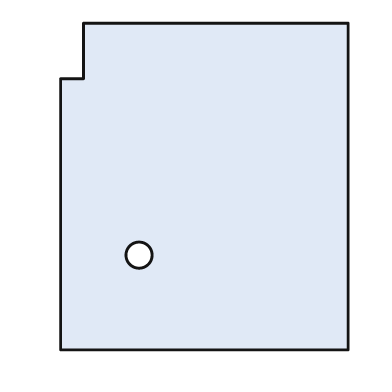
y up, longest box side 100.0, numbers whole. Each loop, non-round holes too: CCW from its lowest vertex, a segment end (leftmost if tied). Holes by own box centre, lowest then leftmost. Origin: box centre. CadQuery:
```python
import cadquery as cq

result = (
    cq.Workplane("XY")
    .moveTo(-44.0, -50.0)
    .lineTo(44.0, -50.0)
    .lineTo(44.0, 50.0)
    .lineTo(-37.0, 50.0)
    .lineTo(-37.0, 33.0)
    .lineTo(-44.0, 33.0)
    .close()
    .moveTo(-20.0, -21.0)
    .circle(4.0)
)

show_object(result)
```